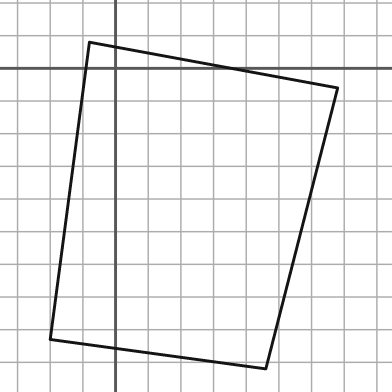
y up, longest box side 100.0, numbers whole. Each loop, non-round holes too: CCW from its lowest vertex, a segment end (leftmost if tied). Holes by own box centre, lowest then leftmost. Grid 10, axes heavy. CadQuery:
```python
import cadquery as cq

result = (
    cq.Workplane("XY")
    .moveTo(46.0, -92.0)
    .lineTo(68.0, -6.0)
    .lineTo(-8.0, 8.0)
    .lineTo(-20.0, -83.0)
    .close()
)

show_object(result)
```